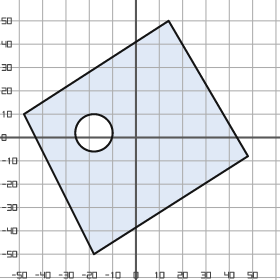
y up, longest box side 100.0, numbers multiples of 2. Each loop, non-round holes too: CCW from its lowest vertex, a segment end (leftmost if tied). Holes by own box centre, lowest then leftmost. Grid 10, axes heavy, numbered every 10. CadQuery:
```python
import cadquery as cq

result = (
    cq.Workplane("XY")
    .moveTo(-18.0, -50.0)
    .lineTo(48.0, -8.0)
    .lineTo(14.0, 50.0)
    .lineTo(-48.0, 10.0)
    .close()
    .moveTo(-18.0, 2.0)
    .circle(8.0)
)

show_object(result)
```